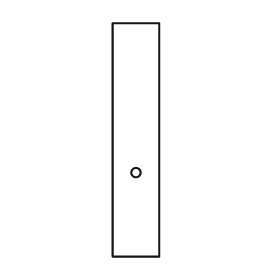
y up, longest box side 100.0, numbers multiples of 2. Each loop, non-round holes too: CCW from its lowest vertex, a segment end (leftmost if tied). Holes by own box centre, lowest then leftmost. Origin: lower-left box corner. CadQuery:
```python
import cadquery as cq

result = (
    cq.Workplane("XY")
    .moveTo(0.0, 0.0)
    .lineTo(20.0, 0.0)
    .lineTo(20.0, 100.0)
    .lineTo(0.0, 100.0)
    .close()
    .moveTo(10.0, 36.0)
    .circle(2.0)
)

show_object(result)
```